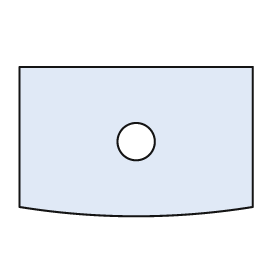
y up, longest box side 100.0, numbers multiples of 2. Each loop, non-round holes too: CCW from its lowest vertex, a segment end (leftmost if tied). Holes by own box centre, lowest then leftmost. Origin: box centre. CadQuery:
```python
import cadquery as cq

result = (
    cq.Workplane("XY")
    .moveTo(-50.0, -28.0)
    .threePointArc((0.0, -32.0), (50.0, -28.0))
    .lineTo(50.0, 32.0)
    .lineTo(-50.0, 32.0)
    .close()
    .moveTo(0.0, 0.0)
    .circle(8.0)
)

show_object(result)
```